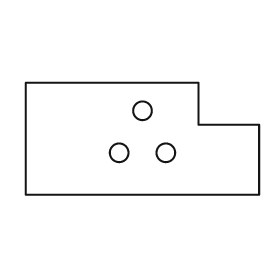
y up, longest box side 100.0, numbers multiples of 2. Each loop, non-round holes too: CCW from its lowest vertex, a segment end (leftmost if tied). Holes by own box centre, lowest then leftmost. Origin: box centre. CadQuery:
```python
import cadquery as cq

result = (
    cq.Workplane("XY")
    .moveTo(-50.0, -24.0)
    .lineTo(50.0, -24.0)
    .lineTo(50.0, 6.0)
    .lineTo(24.0, 6.0)
    .lineTo(24.0, 24.0)
    .lineTo(-50.0, 24.0)
    .close()
    .moveTo(-10.0, -6.0)
    .circle(4.0)
    .moveTo(10.0, -6.0)
    .circle(4.0)
    .moveTo(0.0, 12.0)
    .circle(4.0)
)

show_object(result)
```